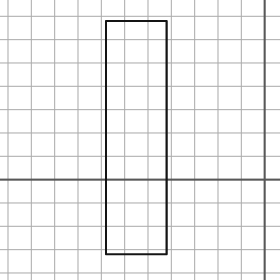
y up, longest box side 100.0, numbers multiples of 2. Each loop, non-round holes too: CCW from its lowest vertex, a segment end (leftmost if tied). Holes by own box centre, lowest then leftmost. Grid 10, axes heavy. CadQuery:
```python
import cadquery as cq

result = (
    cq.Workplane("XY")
    .moveTo(-68.0, -32.0)
    .lineTo(-42.0, -32.0)
    .lineTo(-42.0, 68.0)
    .lineTo(-68.0, 68.0)
    .close()
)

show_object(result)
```